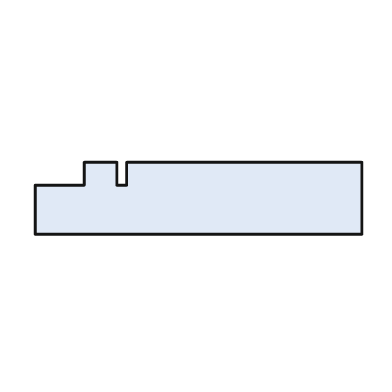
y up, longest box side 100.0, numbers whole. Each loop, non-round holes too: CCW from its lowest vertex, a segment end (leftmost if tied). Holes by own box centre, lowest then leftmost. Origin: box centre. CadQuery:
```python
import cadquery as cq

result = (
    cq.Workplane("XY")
    .moveTo(-50.0, -11.0)
    .lineTo(50.0, -11.0)
    .lineTo(50.0, 11.0)
    .lineTo(-22.0, 11.0)
    .lineTo(-22.0, 4.0)
    .lineTo(-25.0, 4.0)
    .lineTo(-25.0, 11.0)
    .lineTo(-35.0, 11.0)
    .lineTo(-35.0, 4.0)
    .lineTo(-50.0, 4.0)
    .close()
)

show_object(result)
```